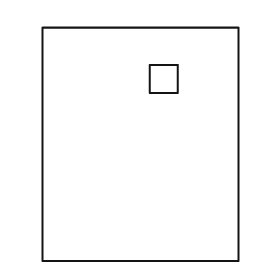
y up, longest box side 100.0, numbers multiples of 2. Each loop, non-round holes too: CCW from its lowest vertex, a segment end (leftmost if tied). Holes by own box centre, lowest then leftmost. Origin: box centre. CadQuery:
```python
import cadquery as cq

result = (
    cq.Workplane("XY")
    .moveTo(-42.0, -50.0)
    .lineTo(42.0, -50.0)
    .lineTo(42.0, 50.0)
    .lineTo(-42.0, 50.0)
    .close()
    .moveTo(4.0, 22.0)
    .lineTo(16.0, 22.0)
    .lineTo(16.0, 34.0)
    .lineTo(4.0, 34.0)
    .close()
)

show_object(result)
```